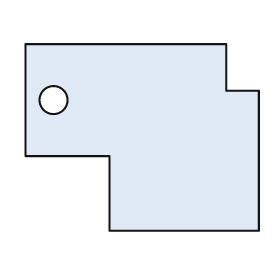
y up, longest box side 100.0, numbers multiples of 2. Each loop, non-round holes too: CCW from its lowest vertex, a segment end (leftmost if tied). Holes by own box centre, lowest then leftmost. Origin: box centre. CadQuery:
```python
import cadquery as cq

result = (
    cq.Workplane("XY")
    .moveTo(-14.0, -40.0)
    .lineTo(50.0, -40.0)
    .lineTo(50.0, 20.0)
    .lineTo(36.0, 20.0)
    .lineTo(36.0, 40.0)
    .lineTo(-50.0, 40.0)
    .lineTo(-50.0, -8.0)
    .lineTo(-14.0, -8.0)
    .close()
    .moveTo(-38.0, 16.0)
    .circle(6.0)
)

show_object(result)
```